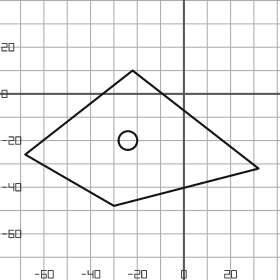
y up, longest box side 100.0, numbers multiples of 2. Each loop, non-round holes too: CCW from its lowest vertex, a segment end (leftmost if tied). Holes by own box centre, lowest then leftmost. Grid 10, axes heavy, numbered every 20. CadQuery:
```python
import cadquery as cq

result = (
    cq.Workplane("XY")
    .moveTo(-30.0, -48.0)
    .lineTo(32.0, -32.0)
    .lineTo(-22.0, 10.0)
    .lineTo(-68.0, -26.0)
    .close()
    .moveTo(-24.0, -20.0)
    .circle(4.0)
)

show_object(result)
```